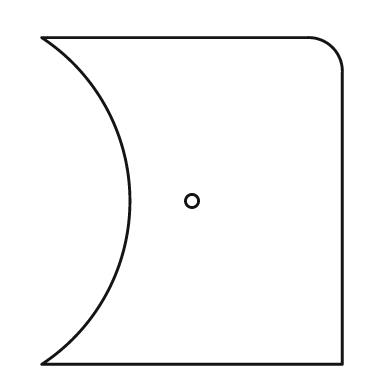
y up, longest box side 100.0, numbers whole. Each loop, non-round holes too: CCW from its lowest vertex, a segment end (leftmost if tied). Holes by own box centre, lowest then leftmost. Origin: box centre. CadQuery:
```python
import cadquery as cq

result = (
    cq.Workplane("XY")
    .moveTo(-46.0, -50.0)
    .lineTo(46.0, -50.0)
    .lineTo(46.0, 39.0)
    .threePointArc((43.0, 47.0), (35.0, 50.0))
    .lineTo(-46.0, 50.0)
    .threePointArc((-19.0, 0.0), (-46.0, -50.0))
    .close()
    .moveTo(0.0, 0.0)
    .circle(2.0)
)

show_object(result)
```